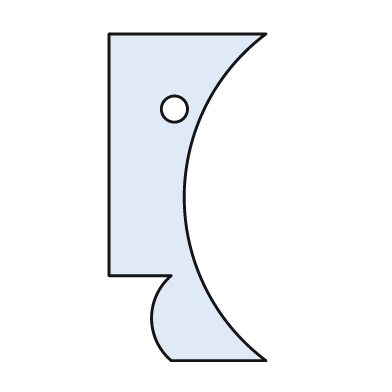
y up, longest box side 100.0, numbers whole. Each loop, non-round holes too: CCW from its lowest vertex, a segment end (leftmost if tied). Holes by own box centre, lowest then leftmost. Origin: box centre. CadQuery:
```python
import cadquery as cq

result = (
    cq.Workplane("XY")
    .moveTo(-5.0, -50.0)
    .lineTo(24.0, -50.0)
    .threePointArc((-1.0, 0.0), (24.0, 50.0))
    .lineTo(-24.0, 50.0)
    .lineTo(-24.0, -24.0)
    .lineTo(-5.0, -24.0)
    .threePointArc((-11.0, -37.0), (-5.0, -50.0))
    .close()
    .moveTo(-4.0, 27.0)
    .circle(4.0)
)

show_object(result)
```